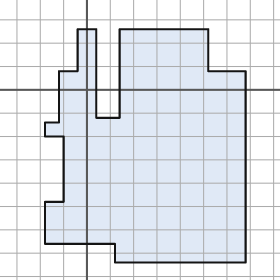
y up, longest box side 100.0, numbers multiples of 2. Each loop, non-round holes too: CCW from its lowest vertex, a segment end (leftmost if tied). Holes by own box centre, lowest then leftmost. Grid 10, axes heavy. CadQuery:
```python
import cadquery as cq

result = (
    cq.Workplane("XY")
    .moveTo(12.0, -74.0)
    .lineTo(68.0, -74.0)
    .lineTo(68.0, 8.0)
    .lineTo(52.0, 8.0)
    .lineTo(52.0, 26.0)
    .lineTo(14.0, 26.0)
    .lineTo(14.0, -12.0)
    .lineTo(4.0, -12.0)
    .lineTo(4.0, 26.0)
    .lineTo(-4.0, 26.0)
    .lineTo(-4.0, 8.0)
    .lineTo(-12.0, 8.0)
    .lineTo(-12.0, -14.0)
    .lineTo(-18.0, -14.0)
    .lineTo(-18.0, -20.0)
    .lineTo(-10.0, -20.0)
    .lineTo(-10.0, -48.0)
    .lineTo(-18.0, -48.0)
    .lineTo(-18.0, -66.0)
    .lineTo(12.0, -66.0)
    .close()
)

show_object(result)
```